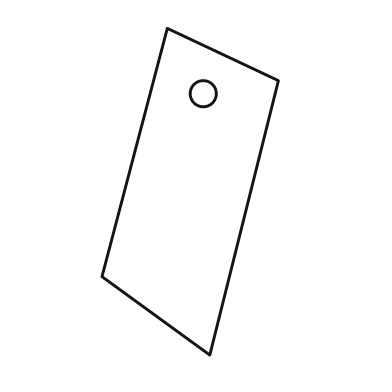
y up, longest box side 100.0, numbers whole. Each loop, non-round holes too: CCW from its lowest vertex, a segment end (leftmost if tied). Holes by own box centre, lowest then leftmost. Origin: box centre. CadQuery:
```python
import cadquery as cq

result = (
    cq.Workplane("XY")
    .moveTo(6.0, -50.0)
    .lineTo(27.0, 34.0)
    .lineTo(-7.0, 50.0)
    .lineTo(-27.0, -26.0)
    .close()
    .moveTo(4.0, 30.0)
    .circle(4.0)
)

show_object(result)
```